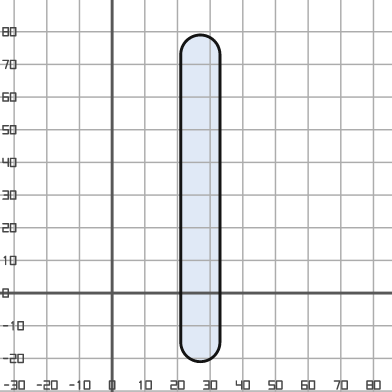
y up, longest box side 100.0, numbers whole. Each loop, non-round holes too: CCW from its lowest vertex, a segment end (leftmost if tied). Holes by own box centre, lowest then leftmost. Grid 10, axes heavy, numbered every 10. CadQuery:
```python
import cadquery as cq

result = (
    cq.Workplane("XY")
    .moveTo(21.0, -15.0)
    .threePointArc((27.0, -21.0), (33.0, -15.0))
    .lineTo(33.0, 73.0)
    .threePointArc((27.0, 79.0), (21.0, 73.0))
    .close()
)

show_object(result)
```